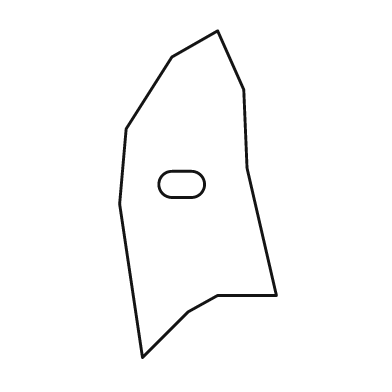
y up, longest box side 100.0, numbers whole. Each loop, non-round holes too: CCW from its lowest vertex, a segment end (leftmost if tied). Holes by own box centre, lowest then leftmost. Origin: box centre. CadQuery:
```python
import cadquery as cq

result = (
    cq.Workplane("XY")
    .moveTo(-17.0, -50.0)
    .lineTo(-3.0, -36.0)
    .lineTo(6.0, -31.0)
    .lineTo(24.0, -31.0)
    .lineTo(15.0, 8.0)
    .lineTo(14.0, 32.0)
    .lineTo(6.0, 50.0)
    .lineTo(-8.0, 42.0)
    .lineTo(-22.0, 20.0)
    .lineTo(-24.0, -3.0)
    .close()
    .moveTo(-8.0, -1.0)
    .lineTo(-2.0, -1.0)
    .threePointArc((2.0, 3.0), (-2.0, 7.0))
    .lineTo(-8.0, 7.0)
    .threePointArc((-12.0, 3.0), (-8.0, -1.0))
    .close()
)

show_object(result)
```